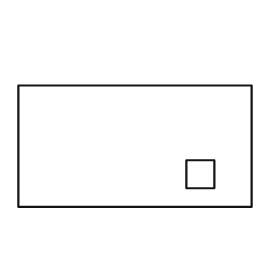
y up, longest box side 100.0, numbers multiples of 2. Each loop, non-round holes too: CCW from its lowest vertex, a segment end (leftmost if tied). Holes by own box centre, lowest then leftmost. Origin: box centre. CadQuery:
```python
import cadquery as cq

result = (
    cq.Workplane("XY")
    .moveTo(-50.0, -26.0)
    .lineTo(50.0, -26.0)
    .lineTo(50.0, 26.0)
    .lineTo(-50.0, 26.0)
    .close()
    .moveTo(22.0, -18.0)
    .lineTo(34.0, -18.0)
    .lineTo(34.0, -6.0)
    .lineTo(22.0, -6.0)
    .close()
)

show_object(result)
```